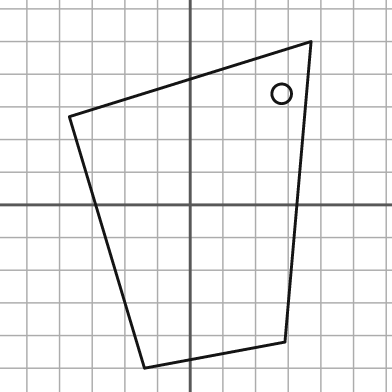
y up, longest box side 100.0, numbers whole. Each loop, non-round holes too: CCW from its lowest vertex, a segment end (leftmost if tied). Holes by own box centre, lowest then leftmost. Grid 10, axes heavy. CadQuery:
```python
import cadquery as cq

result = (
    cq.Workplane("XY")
    .moveTo(-14.0, -50.0)
    .lineTo(29.0, -42.0)
    .lineTo(37.0, 50.0)
    .lineTo(-37.0, 27.0)
    .close()
    .moveTo(28.0, 34.0)
    .circle(3.0)
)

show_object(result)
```